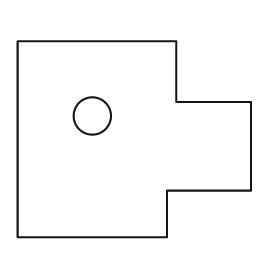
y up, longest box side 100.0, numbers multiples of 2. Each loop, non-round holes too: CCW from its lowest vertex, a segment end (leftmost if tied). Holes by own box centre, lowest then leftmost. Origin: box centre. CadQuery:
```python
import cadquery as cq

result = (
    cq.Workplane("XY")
    .moveTo(-50.0, -42.0)
    .lineTo(14.0, -42.0)
    .lineTo(14.0, -22.0)
    .lineTo(50.0, -22.0)
    .lineTo(50.0, 16.0)
    .lineTo(18.0, 16.0)
    .lineTo(18.0, 42.0)
    .lineTo(-50.0, 42.0)
    .close()
    .moveTo(-18.0, 10.0)
    .circle(8.0)
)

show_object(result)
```